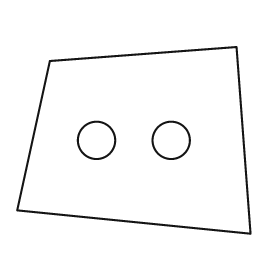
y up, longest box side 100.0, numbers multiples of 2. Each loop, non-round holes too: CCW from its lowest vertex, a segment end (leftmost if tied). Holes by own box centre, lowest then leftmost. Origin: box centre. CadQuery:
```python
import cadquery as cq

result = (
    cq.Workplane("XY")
    .moveTo(50.0, -40.0)
    .lineTo(44.0, 40.0)
    .lineTo(-36.0, 34.0)
    .lineTo(-50.0, -30.0)
    .close()
    .moveTo(-16.0, 0.0)
    .circle(8.0)
    .moveTo(16.0, 0.0)
    .circle(8.0)
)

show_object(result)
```